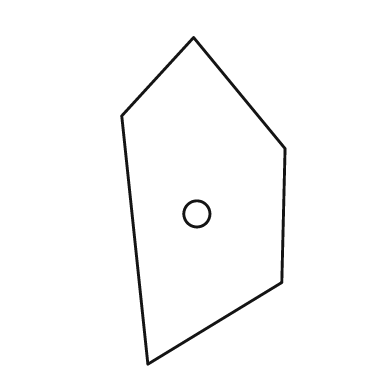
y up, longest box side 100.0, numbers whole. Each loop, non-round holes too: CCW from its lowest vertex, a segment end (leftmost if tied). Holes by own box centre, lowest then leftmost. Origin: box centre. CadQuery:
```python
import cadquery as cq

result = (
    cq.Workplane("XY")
    .moveTo(-17.0, -50.0)
    .lineTo(24.0, -25.0)
    .lineTo(25.0, 16.0)
    .lineTo(-3.0, 50.0)
    .lineTo(-25.0, 26.0)
    .close()
    .moveTo(-2.0, -4.0)
    .circle(4.0)
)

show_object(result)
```